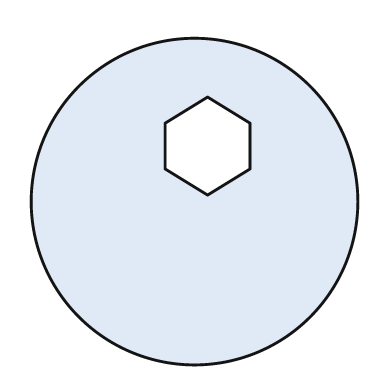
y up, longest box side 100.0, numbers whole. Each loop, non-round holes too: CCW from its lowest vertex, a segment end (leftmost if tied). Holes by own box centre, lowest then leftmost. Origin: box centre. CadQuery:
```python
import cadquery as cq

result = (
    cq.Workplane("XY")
    .moveTo(0.0, 0.0)
    .circle(50.0)
    .moveTo(4.0, 2.0)
    .lineTo(17.0, 10.0)
    .lineTo(17.0, 24.0)
    .lineTo(4.0, 32.0)
    .lineTo(-9.0, 24.0)
    .lineTo(-9.0, 10.0)
    .close()
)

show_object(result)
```